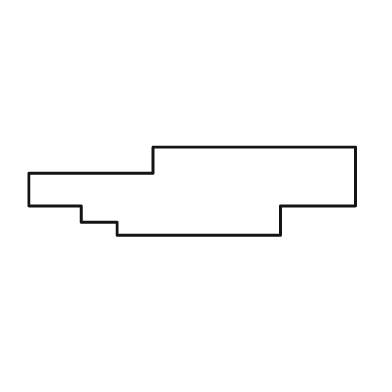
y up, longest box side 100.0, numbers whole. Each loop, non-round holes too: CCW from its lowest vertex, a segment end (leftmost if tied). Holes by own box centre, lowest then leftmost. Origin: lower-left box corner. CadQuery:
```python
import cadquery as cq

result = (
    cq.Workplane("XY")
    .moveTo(27.0, 0.0)
    .lineTo(77.0, 0.0)
    .lineTo(77.0, 9.0)
    .lineTo(100.0, 9.0)
    .lineTo(100.0, 27.0)
    .lineTo(38.0, 27.0)
    .lineTo(38.0, 19.0)
    .lineTo(0.0, 19.0)
    .lineTo(0.0, 9.0)
    .lineTo(16.0, 9.0)
    .lineTo(16.0, 4.0)
    .lineTo(27.0, 4.0)
    .close()
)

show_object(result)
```